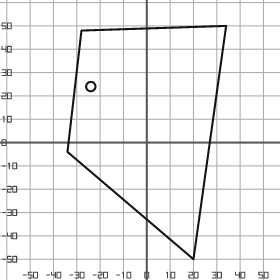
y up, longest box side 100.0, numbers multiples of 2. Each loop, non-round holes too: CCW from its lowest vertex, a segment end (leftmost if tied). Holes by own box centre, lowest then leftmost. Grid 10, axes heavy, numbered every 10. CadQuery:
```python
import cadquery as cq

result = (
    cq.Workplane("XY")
    .moveTo(20.0, -50.0)
    .lineTo(34.0, 50.0)
    .lineTo(-28.0, 48.0)
    .lineTo(-34.0, -4.0)
    .close()
    .moveTo(-24.0, 24.0)
    .circle(2.0)
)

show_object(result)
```